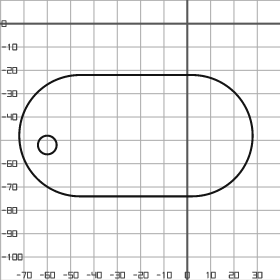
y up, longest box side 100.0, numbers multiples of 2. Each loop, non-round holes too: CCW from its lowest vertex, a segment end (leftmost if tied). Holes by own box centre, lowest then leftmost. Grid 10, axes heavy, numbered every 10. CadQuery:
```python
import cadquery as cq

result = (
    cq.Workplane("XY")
    .moveTo(-46.0, -74.0)
    .lineTo(2.0, -74.0)
    .threePointArc((28.0, -48.0), (2.0, -22.0))
    .lineTo(-46.0, -22.0)
    .threePointArc((-72.0, -48.0), (-46.0, -74.0))
    .close()
    .moveTo(-60.0, -52.0)
    .circle(4.0)
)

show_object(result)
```